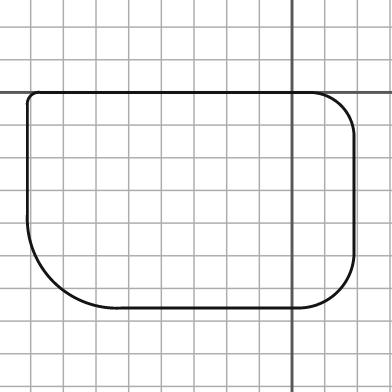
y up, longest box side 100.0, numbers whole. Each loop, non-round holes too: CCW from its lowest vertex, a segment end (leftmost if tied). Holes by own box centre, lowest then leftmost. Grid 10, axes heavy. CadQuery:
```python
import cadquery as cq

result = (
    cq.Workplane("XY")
    .moveTo(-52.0, -66.0)
    .lineTo(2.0, -66.0)
    .threePointArc((14.0, -61.0), (19.0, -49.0))
    .lineTo(19.0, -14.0)
    .threePointArc((15.0, -4.0), (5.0, 0.0))
    .lineTo(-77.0, 0.0)
    .threePointArc((-80.0, -1.0), (-81.0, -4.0))
    .lineTo(-81.0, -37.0)
    .threePointArc((-73.0, -58.0), (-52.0, -66.0))
    .close()
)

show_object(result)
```